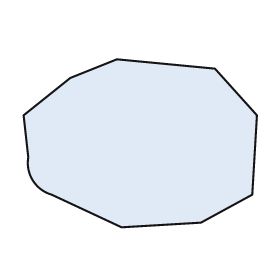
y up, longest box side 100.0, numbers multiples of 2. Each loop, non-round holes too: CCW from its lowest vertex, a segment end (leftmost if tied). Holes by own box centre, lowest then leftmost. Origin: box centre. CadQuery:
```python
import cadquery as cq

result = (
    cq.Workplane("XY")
    .moveTo(-8.0, -36.0)
    .lineTo(26.0, -34.0)
    .lineTo(48.0, -22.0)
    .lineTo(50.0, 12.0)
    .lineTo(32.0, 32.0)
    .lineTo(-10.0, 36.0)
    .lineTo(-30.0, 28.0)
    .lineTo(-50.0, 12.0)
    .lineTo(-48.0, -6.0)
    .threePointArc((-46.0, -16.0), (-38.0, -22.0))
    .close()
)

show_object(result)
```